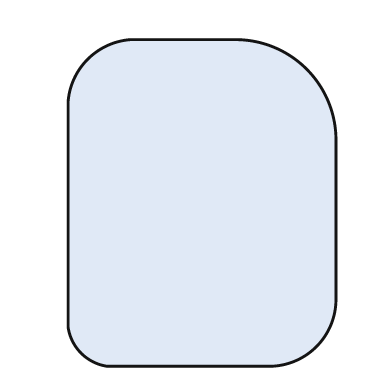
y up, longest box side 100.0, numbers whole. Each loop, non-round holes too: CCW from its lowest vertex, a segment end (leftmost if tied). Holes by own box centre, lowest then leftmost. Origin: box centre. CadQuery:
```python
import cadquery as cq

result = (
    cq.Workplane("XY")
    .moveTo(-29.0, -50.0)
    .lineTo(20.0, -50.0)
    .threePointArc((35.0, -44.0), (41.0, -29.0))
    .lineTo(41.0, 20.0)
    .threePointArc((32.0, 41.0), (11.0, 50.0))
    .lineTo(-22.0, 50.0)
    .threePointArc((-35.0, 44.0), (-41.0, 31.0))
    .lineTo(-41.0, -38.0)
    .threePointArc((-37.0, -46.0), (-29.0, -50.0))
    .close()
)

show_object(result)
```